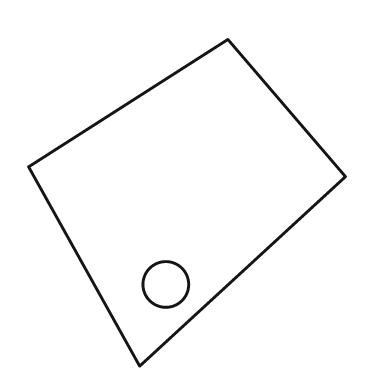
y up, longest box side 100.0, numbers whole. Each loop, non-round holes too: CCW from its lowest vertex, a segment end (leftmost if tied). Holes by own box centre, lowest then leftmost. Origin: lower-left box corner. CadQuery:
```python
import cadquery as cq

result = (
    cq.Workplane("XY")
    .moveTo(34.0, 0.0)
    .lineTo(97.0, 58.0)
    .lineTo(61.0, 100.0)
    .lineTo(0.0, 61.0)
    .close()
    .moveTo(42.0, 25.0)
    .circle(7.0)
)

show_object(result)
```